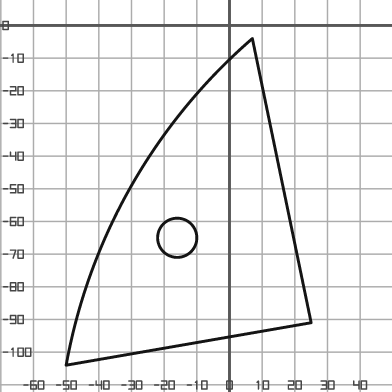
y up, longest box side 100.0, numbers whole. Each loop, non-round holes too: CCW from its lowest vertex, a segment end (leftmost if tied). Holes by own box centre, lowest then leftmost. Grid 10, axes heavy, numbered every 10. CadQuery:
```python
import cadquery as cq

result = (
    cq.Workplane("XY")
    .moveTo(-50.0, -104.0)
    .lineTo(25.0, -91.0)
    .lineTo(7.0, -4.0)
    .threePointArc((-30.0, -49.0), (-50.0, -104.0))
    .close()
    .moveTo(-16.0, -65.0)
    .circle(6.0)
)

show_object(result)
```